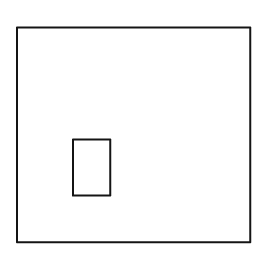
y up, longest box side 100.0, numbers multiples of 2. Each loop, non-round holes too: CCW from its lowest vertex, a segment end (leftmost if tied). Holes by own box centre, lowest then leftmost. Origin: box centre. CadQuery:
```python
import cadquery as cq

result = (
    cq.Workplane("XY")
    .moveTo(-50.0, -46.0)
    .lineTo(50.0, -46.0)
    .lineTo(50.0, 46.0)
    .lineTo(-50.0, 46.0)
    .close()
    .moveTo(-26.0, -26.0)
    .lineTo(-10.0, -26.0)
    .lineTo(-10.0, -2.0)
    .lineTo(-26.0, -2.0)
    .close()
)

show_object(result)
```